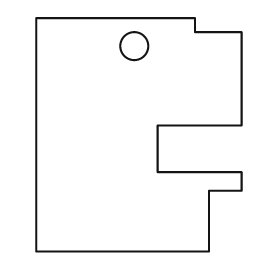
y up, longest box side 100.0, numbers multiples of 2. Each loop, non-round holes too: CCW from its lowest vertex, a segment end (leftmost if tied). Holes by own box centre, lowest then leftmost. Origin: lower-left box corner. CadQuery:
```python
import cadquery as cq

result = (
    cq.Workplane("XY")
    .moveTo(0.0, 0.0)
    .lineTo(74.0, 0.0)
    .lineTo(74.0, 26.0)
    .lineTo(88.0, 26.0)
    .lineTo(88.0, 34.0)
    .lineTo(52.0, 34.0)
    .lineTo(52.0, 54.0)
    .lineTo(88.0, 54.0)
    .lineTo(88.0, 94.0)
    .lineTo(68.0, 94.0)
    .lineTo(68.0, 100.0)
    .lineTo(0.0, 100.0)
    .close()
    .moveTo(42.0, 88.0)
    .circle(6.0)
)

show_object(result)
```